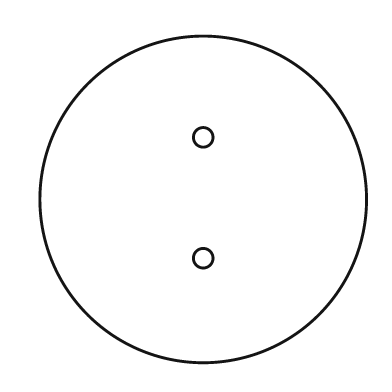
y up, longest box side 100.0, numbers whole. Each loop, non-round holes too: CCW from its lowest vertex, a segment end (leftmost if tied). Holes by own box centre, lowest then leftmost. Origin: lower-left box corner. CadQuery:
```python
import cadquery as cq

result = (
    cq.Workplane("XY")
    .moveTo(50.0, 50.0)
    .circle(50.0)
    .moveTo(50.0, 32.0)
    .circle(3.0)
    .moveTo(50.0, 69.0)
    .circle(3.0)
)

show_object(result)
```